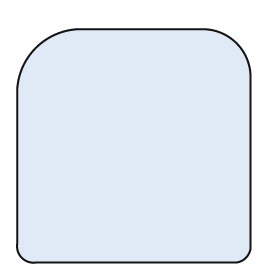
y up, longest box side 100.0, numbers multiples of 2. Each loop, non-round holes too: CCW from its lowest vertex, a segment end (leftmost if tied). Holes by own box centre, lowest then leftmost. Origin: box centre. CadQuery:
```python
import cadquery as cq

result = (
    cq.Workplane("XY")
    .moveTo(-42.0, -50.0)
    .lineTo(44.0, -50.0)
    .threePointArc((48.0, -48.0), (50.0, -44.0))
    .lineTo(50.0, 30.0)
    .threePointArc((44.0, 44.0), (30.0, 50.0))
    .lineTo(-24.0, 50.0)
    .threePointArc((-42.0, 42.0), (-50.0, 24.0))
    .lineTo(-50.0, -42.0)
    .threePointArc((-48.0, -48.0), (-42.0, -50.0))
    .close()
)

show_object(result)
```